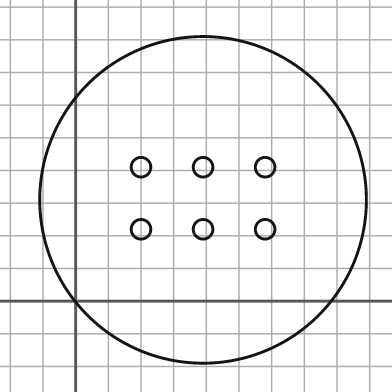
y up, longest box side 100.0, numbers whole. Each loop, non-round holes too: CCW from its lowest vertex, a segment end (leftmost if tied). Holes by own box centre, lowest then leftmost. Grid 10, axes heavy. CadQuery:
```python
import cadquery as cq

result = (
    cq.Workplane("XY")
    .moveTo(39.0, 31.0)
    .circle(50.0)
    .moveTo(20.0, 22.0)
    .circle(3.0)
    .moveTo(39.0, 22.0)
    .circle(3.0)
    .moveTo(58.0, 22.0)
    .circle(3.0)
    .moveTo(20.0, 41.0)
    .circle(3.0)
    .moveTo(39.0, 41.0)
    .circle(3.0)
    .moveTo(58.0, 41.0)
    .circle(3.0)
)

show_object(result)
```